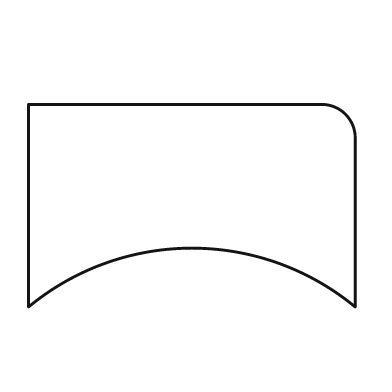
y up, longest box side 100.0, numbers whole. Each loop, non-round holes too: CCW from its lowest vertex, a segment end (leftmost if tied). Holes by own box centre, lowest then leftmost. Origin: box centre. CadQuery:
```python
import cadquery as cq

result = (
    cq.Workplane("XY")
    .moveTo(-50.0, -31.0)
    .threePointArc((0.0, -13.0), (50.0, -31.0))
    .lineTo(50.0, 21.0)
    .threePointArc((47.0, 28.0), (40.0, 31.0))
    .lineTo(-50.0, 31.0)
    .close()
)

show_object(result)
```